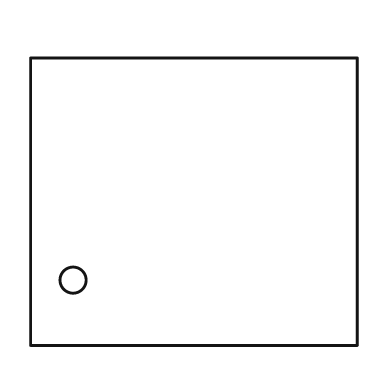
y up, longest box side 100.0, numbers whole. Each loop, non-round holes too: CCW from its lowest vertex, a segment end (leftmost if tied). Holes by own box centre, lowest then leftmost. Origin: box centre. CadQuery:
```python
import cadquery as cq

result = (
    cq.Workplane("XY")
    .moveTo(-50.0, -44.0)
    .lineTo(50.0, -44.0)
    .lineTo(50.0, 44.0)
    .lineTo(-50.0, 44.0)
    .close()
    .moveTo(-37.0, -24.0)
    .circle(4.0)
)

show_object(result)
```